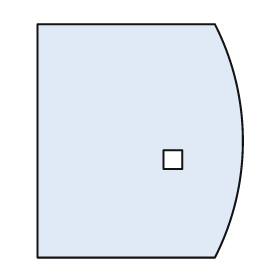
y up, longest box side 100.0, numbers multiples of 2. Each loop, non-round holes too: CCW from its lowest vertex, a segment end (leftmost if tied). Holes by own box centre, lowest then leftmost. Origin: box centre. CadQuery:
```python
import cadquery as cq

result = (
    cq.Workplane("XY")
    .moveTo(-44.0, -50.0)
    .lineTo(32.0, -50.0)
    .threePointArc((44.0, 0.0), (32.0, 50.0))
    .lineTo(-44.0, 50.0)
    .close()
    .moveTo(10.0, -12.0)
    .lineTo(18.0, -12.0)
    .lineTo(18.0, -4.0)
    .lineTo(10.0, -4.0)
    .close()
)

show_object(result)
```